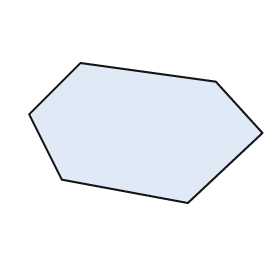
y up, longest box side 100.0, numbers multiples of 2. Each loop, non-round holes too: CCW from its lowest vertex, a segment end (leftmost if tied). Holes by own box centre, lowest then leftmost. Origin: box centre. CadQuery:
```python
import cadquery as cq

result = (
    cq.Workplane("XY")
    .moveTo(18.0, -30.0)
    .lineTo(50.0, 0.0)
    .lineTo(30.0, 22.0)
    .lineTo(-28.0, 30.0)
    .lineTo(-50.0, 8.0)
    .lineTo(-36.0, -20.0)
    .close()
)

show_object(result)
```